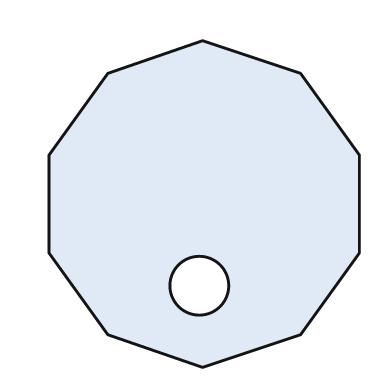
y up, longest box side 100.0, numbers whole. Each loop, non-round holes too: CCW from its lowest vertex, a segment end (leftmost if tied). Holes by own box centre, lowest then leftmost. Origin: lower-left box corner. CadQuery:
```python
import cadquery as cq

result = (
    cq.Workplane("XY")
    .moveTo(47.0, 0.0)
    .lineTo(77.0, 10.0)
    .lineTo(95.0, 35.0)
    .lineTo(95.0, 65.0)
    .lineTo(77.0, 90.0)
    .lineTo(47.0, 100.0)
    .lineTo(18.0, 90.0)
    .lineTo(0.0, 65.0)
    .lineTo(0.0, 35.0)
    .lineTo(18.0, 10.0)
    .close()
    .moveTo(46.0, 25.0)
    .circle(9.0)
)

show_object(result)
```